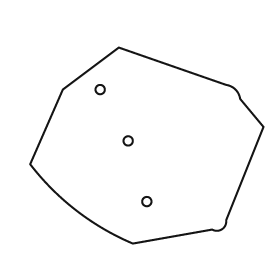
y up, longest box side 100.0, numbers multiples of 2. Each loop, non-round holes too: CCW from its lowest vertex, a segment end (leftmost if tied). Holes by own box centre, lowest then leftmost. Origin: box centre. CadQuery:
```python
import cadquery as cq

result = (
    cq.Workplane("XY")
    .moveTo(-6.0, -42.0)
    .lineTo(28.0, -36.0)
    .threePointArc((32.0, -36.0), (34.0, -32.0))
    .lineTo(50.0, 8.0)
    .lineTo(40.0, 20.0)
    .threePointArc((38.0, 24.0), (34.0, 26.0))
    .lineTo(-12.0, 42.0)
    .lineTo(-36.0, 24.0)
    .lineTo(-50.0, -8.0)
    .threePointArc((-30.0, -28.0), (-6.0, -42.0))
    .close()
    .moveTo(0.0, -24.0)
    .circle(2.0)
    .moveTo(-8.0, 2.0)
    .circle(2.0)
    .moveTo(-20.0, 24.0)
    .circle(2.0)
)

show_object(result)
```